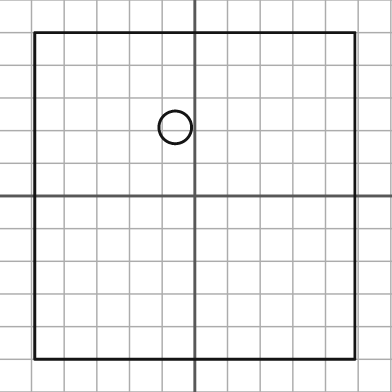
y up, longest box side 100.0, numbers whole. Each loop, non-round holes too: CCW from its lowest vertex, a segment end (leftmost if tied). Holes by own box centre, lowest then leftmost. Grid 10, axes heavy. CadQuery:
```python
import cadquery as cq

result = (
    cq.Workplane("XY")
    .moveTo(-49.0, -50.0)
    .lineTo(49.0, -50.0)
    .lineTo(49.0, 50.0)
    .lineTo(-49.0, 50.0)
    .close()
    .moveTo(-6.0, 21.0)
    .circle(5.0)
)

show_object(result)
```